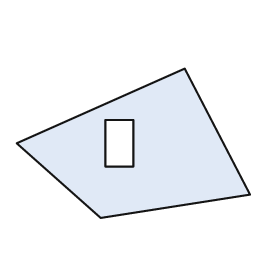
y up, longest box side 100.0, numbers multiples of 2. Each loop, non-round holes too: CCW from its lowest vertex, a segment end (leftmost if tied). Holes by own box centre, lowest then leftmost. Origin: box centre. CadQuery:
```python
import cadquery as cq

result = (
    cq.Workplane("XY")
    .moveTo(-14.0, -32.0)
    .lineTo(50.0, -22.0)
    .lineTo(22.0, 32.0)
    .lineTo(-50.0, 0.0)
    .close()
    .moveTo(-12.0, -10.0)
    .lineTo(0.0, -10.0)
    .lineTo(0.0, 10.0)
    .lineTo(-12.0, 10.0)
    .close()
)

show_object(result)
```